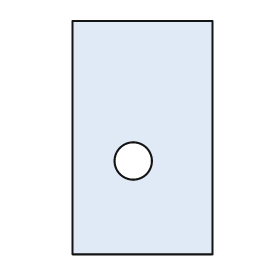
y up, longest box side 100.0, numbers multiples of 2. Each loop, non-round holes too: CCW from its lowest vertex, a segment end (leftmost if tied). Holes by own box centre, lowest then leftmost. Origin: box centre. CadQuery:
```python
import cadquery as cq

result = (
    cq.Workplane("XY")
    .moveTo(-30.0, -50.0)
    .lineTo(30.0, -50.0)
    .lineTo(30.0, 50.0)
    .lineTo(-30.0, 50.0)
    .close()
    .moveTo(-4.0, -10.0)
    .circle(8.0)
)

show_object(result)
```